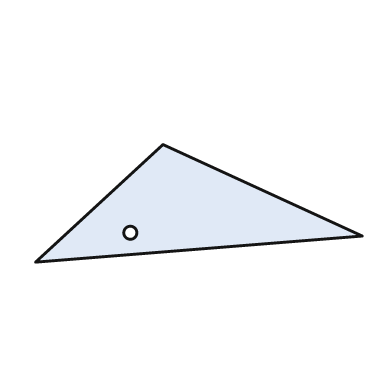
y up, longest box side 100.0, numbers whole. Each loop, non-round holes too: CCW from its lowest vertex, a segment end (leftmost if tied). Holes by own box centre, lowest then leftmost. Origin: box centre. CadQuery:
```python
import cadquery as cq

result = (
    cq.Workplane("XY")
    .moveTo(-50.0, -18.0)
    .lineTo(50.0, -10.0)
    .lineTo(-11.0, 18.0)
    .close()
    .moveTo(-21.0, -9.0)
    .circle(2.0)
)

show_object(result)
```